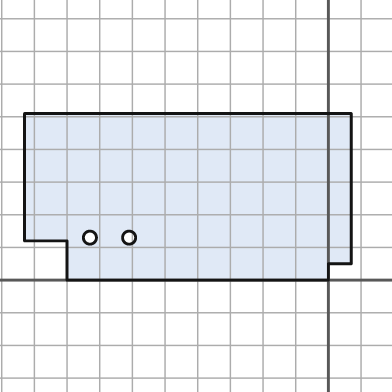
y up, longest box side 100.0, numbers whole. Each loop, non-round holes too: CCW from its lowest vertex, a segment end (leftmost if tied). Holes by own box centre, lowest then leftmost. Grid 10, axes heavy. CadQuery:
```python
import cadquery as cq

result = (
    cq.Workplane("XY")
    .moveTo(-80.0, 0.0)
    .lineTo(0.0, 0.0)
    .lineTo(0.0, 5.0)
    .lineTo(7.0, 5.0)
    .lineTo(7.0, 51.0)
    .lineTo(-93.0, 51.0)
    .lineTo(-93.0, 12.0)
    .lineTo(-80.0, 12.0)
    .close()
    .moveTo(-73.0, 13.0)
    .circle(2.0)
    .moveTo(-61.0, 13.0)
    .circle(2.0)
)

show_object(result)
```